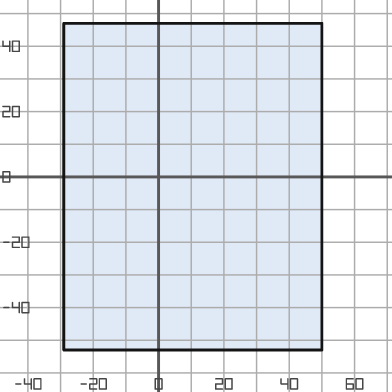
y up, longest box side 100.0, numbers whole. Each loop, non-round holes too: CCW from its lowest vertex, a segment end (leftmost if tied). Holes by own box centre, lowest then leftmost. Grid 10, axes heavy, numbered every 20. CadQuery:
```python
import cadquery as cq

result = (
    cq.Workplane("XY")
    .moveTo(-29.0, -53.0)
    .lineTo(50.0, -53.0)
    .lineTo(50.0, 47.0)
    .lineTo(-29.0, 47.0)
    .close()
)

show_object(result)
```